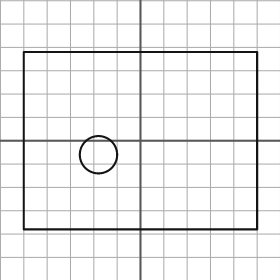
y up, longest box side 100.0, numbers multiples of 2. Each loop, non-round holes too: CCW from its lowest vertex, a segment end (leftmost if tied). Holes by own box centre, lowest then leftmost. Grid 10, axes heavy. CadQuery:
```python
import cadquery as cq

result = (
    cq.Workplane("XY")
    .moveTo(-50.0, -38.0)
    .lineTo(50.0, -38.0)
    .lineTo(50.0, 38.0)
    .lineTo(-50.0, 38.0)
    .close()
    .moveTo(-18.0, -6.0)
    .circle(8.0)
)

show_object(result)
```